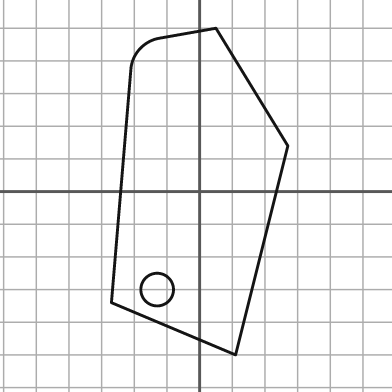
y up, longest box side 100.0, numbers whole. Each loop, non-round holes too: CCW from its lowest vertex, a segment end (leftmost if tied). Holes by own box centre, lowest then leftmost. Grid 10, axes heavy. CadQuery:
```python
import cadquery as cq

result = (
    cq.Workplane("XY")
    .moveTo(11.0, -50.0)
    .lineTo(27.0, 14.0)
    .lineTo(5.0, 50.0)
    .lineTo(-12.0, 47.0)
    .threePointArc((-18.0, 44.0), (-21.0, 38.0))
    .lineTo(-27.0, -34.0)
    .close()
    .moveTo(-13.0, -30.0)
    .circle(5.0)
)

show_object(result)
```